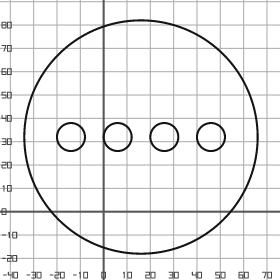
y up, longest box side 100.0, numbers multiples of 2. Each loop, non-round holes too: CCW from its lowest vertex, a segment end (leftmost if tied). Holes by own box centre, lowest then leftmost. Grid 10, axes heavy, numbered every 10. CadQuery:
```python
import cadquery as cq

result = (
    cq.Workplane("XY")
    .moveTo(16.0, 32.0)
    .circle(50.0)
    .moveTo(-14.0, 32.0)
    .circle(6.0)
    .moveTo(6.0, 32.0)
    .circle(6.0)
    .moveTo(26.0, 32.0)
    .circle(6.0)
    .moveTo(46.0, 32.0)
    .circle(6.0)
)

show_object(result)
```